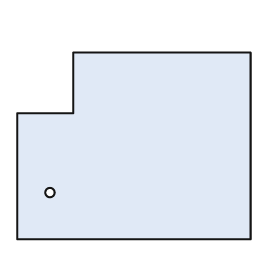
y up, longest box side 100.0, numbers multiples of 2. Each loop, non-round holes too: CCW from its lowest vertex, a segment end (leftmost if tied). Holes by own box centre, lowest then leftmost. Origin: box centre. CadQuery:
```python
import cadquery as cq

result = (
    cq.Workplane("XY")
    .moveTo(-50.0, -40.0)
    .lineTo(50.0, -40.0)
    .lineTo(50.0, 40.0)
    .lineTo(-26.0, 40.0)
    .lineTo(-26.0, 14.0)
    .lineTo(-50.0, 14.0)
    .close()
    .moveTo(-36.0, -20.0)
    .circle(2.0)
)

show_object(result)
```